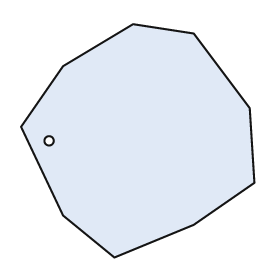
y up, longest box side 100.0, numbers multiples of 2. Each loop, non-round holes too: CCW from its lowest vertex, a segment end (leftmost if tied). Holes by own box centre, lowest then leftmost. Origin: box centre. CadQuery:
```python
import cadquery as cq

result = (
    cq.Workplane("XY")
    .moveTo(-10.0, -50.0)
    .lineTo(24.0, -36.0)
    .lineTo(50.0, -18.0)
    .lineTo(48.0, 14.0)
    .lineTo(24.0, 46.0)
    .lineTo(-2.0, 50.0)
    .lineTo(-32.0, 32.0)
    .lineTo(-50.0, 6.0)
    .lineTo(-32.0, -32.0)
    .close()
    .moveTo(-38.0, 0.0)
    .circle(2.0)
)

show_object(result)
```